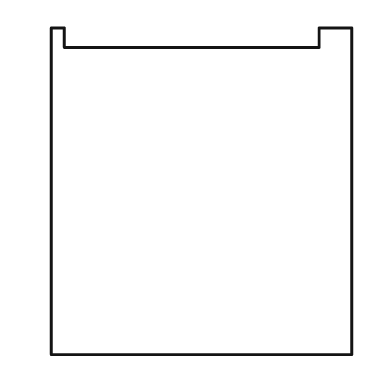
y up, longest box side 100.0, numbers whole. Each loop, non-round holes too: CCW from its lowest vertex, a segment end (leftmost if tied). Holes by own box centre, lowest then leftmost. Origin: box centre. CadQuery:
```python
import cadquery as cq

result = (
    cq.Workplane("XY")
    .moveTo(-46.0, -50.0)
    .lineTo(46.0, -50.0)
    .lineTo(46.0, 50.0)
    .lineTo(36.0, 50.0)
    .lineTo(36.0, 44.0)
    .lineTo(-42.0, 44.0)
    .lineTo(-42.0, 50.0)
    .lineTo(-46.0, 50.0)
    .close()
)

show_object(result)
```